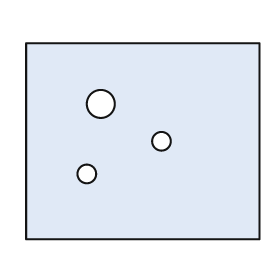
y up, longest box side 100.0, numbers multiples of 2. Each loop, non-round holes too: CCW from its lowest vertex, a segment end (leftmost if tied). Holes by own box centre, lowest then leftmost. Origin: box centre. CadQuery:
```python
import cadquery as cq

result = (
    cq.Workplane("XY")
    .moveTo(-50.0, -42.0)
    .lineTo(50.0, -42.0)
    .lineTo(50.0, 42.0)
    .lineTo(-50.0, 42.0)
    .close()
    .moveTo(-24.0, -14.0)
    .circle(4.0)
    .moveTo(8.0, 0.0)
    .circle(4.0)
    .moveTo(-18.0, 16.0)
    .circle(6.0)
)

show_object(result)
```